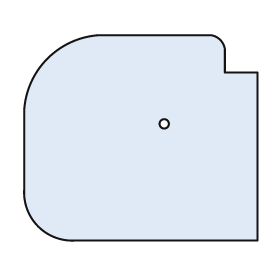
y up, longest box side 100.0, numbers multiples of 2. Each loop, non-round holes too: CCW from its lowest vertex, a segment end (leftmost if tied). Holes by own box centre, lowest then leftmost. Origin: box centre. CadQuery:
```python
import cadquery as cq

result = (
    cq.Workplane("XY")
    .moveTo(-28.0, -44.0)
    .lineTo(50.0, -44.0)
    .lineTo(50.0, 28.0)
    .lineTo(36.0, 28.0)
    .lineTo(36.0, 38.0)
    .threePointArc((34.0, 42.0), (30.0, 44.0))
    .lineTo(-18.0, 44.0)
    .threePointArc((-40.0, 34.0), (-50.0, 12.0))
    .lineTo(-50.0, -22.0)
    .threePointArc((-44.0, -38.0), (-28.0, -44.0))
    .close()
    .moveTo(10.0, 6.0)
    .circle(2.0)
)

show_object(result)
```